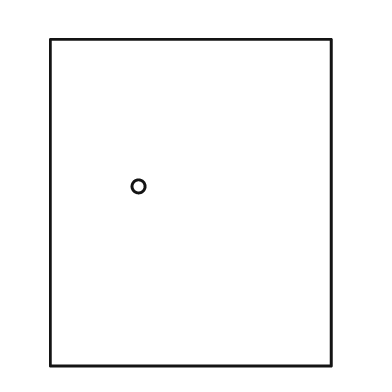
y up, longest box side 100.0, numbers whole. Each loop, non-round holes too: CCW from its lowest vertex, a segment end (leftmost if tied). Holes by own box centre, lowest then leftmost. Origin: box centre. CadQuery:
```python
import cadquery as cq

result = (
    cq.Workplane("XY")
    .moveTo(-43.0, -50.0)
    .lineTo(43.0, -50.0)
    .lineTo(43.0, 50.0)
    .lineTo(-43.0, 50.0)
    .close()
    .moveTo(-16.0, 5.0)
    .circle(2.0)
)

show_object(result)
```